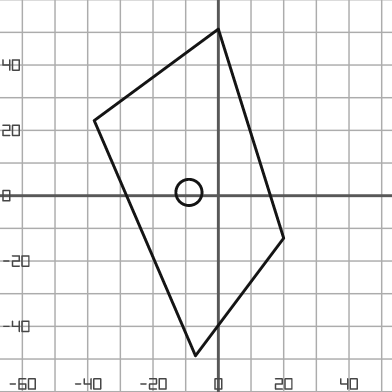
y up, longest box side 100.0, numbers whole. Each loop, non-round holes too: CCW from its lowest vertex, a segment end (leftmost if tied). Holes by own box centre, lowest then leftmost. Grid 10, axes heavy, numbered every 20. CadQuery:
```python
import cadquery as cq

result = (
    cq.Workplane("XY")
    .moveTo(-7.0, -49.0)
    .lineTo(20.0, -13.0)
    .lineTo(0.0, 51.0)
    .lineTo(-38.0, 23.0)
    .close()
    .moveTo(-9.0, 1.0)
    .circle(4.0)
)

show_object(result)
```